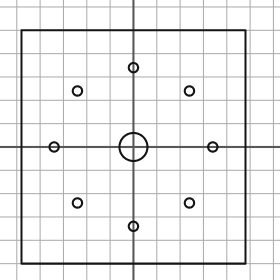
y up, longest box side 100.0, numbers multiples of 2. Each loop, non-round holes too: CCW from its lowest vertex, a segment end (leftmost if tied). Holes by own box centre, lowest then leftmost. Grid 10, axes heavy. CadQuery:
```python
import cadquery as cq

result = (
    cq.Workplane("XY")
    .moveTo(-48.0, -50.0)
    .lineTo(48.0, -50.0)
    .lineTo(48.0, 50.0)
    .lineTo(-48.0, 50.0)
    .close()
    .moveTo(0.0, -34.0)
    .circle(2.0)
    .moveTo(-24.0, -24.0)
    .circle(2.0)
    .moveTo(24.0, -24.0)
    .circle(2.0)
    .moveTo(-34.0, 0.0)
    .circle(2.0)
    .moveTo(0.0, 0.0)
    .circle(6.0)
    .moveTo(34.0, 0.0)
    .circle(2.0)
    .moveTo(-24.0, 24.0)
    .circle(2.0)
    .moveTo(24.0, 24.0)
    .circle(2.0)
    .moveTo(0.0, 34.0)
    .circle(2.0)
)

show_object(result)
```